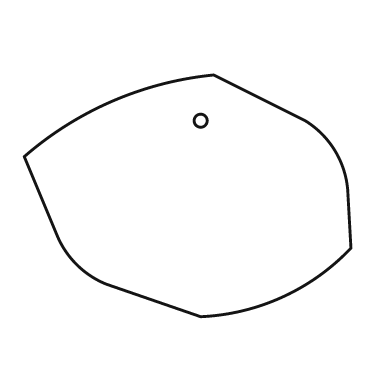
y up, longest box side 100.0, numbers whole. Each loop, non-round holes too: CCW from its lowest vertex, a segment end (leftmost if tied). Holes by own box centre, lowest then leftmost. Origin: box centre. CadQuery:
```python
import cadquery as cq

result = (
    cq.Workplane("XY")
    .moveTo(4.0, -37.0)
    .threePointArc((29.0, -31.0), (50.0, -16.0))
    .lineTo(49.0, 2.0)
    .threePointArc((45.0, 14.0), (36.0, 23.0))
    .lineTo(8.0, 37.0)
    .threePointArc((-23.0, 29.0), (-50.0, 12.0))
    .lineTo(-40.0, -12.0)
    .threePointArc((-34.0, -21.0), (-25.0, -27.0))
    .close()
    .moveTo(4.0, 23.0)
    .circle(2.0)
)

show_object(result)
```